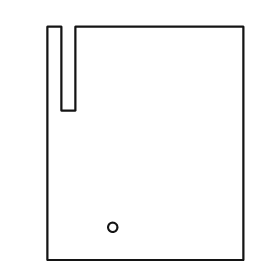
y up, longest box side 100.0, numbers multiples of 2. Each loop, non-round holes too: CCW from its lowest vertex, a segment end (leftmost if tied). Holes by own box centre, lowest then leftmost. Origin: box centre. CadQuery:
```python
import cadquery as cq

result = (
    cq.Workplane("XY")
    .moveTo(-42.0, -50.0)
    .lineTo(42.0, -50.0)
    .lineTo(42.0, 50.0)
    .lineTo(-30.0, 50.0)
    .lineTo(-30.0, 14.0)
    .lineTo(-36.0, 14.0)
    .lineTo(-36.0, 50.0)
    .lineTo(-42.0, 50.0)
    .close()
    .moveTo(-14.0, -36.0)
    .circle(2.0)
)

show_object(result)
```